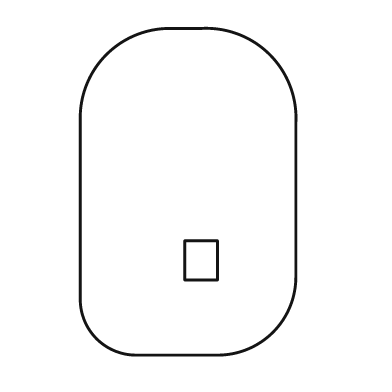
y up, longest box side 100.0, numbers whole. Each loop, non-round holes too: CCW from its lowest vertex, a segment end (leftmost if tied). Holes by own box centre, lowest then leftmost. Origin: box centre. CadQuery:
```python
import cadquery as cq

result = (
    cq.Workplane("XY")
    .moveTo(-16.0, -50.0)
    .lineTo(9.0, -50.0)
    .threePointArc((26.0, -43.0), (33.0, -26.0))
    .lineTo(33.0, 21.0)
    .threePointArc((25.0, 42.0), (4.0, 50.0))
    .lineTo(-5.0, 50.0)
    .threePointArc((-25.0, 42.0), (-33.0, 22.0))
    .lineTo(-33.0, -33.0)
    .threePointArc((-28.0, -45.0), (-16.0, -50.0))
    .close()
    .moveTo(-1.0, -27.0)
    .lineTo(9.0, -27.0)
    .lineTo(9.0, -15.0)
    .lineTo(-1.0, -15.0)
    .close()
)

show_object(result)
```